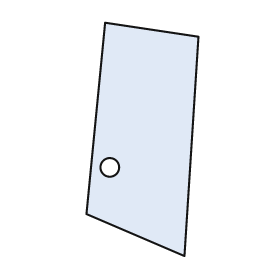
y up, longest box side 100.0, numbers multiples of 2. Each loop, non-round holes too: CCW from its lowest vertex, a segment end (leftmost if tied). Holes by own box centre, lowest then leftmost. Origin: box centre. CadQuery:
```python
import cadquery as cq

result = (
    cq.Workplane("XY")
    .moveTo(18.0, -50.0)
    .lineTo(24.0, 44.0)
    .lineTo(-16.0, 50.0)
    .lineTo(-24.0, -32.0)
    .close()
    .moveTo(-14.0, -12.0)
    .circle(4.0)
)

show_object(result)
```